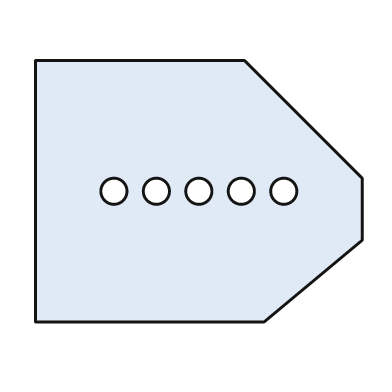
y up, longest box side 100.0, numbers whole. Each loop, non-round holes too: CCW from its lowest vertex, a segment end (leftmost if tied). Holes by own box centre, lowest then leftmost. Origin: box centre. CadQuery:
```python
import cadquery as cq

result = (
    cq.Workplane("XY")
    .moveTo(-50.0, -40.0)
    .lineTo(20.0, -40.0)
    .lineTo(50.0, -15.0)
    .lineTo(50.0, 4.0)
    .lineTo(14.0, 40.0)
    .lineTo(-50.0, 40.0)
    .close()
    .moveTo(-26.0, 0.0)
    .circle(4.0)
    .moveTo(-13.0, 0.0)
    .circle(4.0)
    .moveTo(0.0, 0.0)
    .circle(4.0)
    .moveTo(13.0, 0.0)
    .circle(4.0)
    .moveTo(26.0, 0.0)
    .circle(4.0)
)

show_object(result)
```